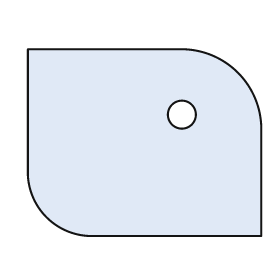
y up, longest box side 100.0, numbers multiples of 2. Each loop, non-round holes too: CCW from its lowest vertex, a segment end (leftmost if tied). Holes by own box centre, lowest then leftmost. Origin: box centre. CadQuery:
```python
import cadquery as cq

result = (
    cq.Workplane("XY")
    .moveTo(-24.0, -40.0)
    .lineTo(50.0, -40.0)
    .lineTo(50.0, 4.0)
    .threePointArc((40.0, 30.0), (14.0, 40.0))
    .lineTo(-50.0, 40.0)
    .lineTo(-50.0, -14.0)
    .threePointArc((-42.0, -32.0), (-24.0, -40.0))
    .close()
    .moveTo(16.0, 12.0)
    .circle(6.0)
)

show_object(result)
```